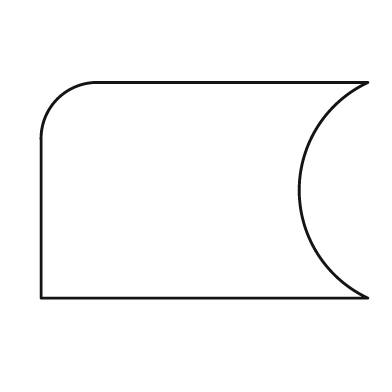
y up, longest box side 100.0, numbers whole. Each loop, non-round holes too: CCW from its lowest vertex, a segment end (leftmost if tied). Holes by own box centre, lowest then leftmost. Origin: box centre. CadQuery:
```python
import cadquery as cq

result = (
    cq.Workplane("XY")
    .moveTo(-50.0, -33.0)
    .lineTo(50.0, -33.0)
    .threePointArc((29.0, 0.0), (50.0, 33.0))
    .lineTo(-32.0, 33.0)
    .threePointArc((-45.0, 28.0), (-50.0, 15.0))
    .close()
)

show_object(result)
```